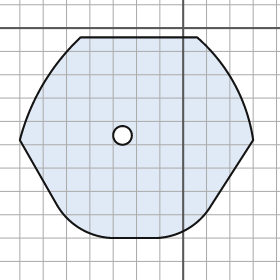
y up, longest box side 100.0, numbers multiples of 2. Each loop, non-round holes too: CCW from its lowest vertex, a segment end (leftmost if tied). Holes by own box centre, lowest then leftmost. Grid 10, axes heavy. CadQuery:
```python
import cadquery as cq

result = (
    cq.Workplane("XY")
    .moveTo(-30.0, -90.0)
    .lineTo(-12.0, -90.0)
    .threePointArc((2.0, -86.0), (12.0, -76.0))
    .lineTo(30.0, -48.0)
    .threePointArc((22.0, -24.0), (6.0, -4.0))
    .lineTo(-44.0, -4.0)
    .threePointArc((-60.0, -24.0), (-70.0, -48.0))
    .lineTo(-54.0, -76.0)
    .threePointArc((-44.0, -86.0), (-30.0, -90.0))
    .close()
    .moveTo(-26.0, -46.0)
    .circle(4.0)
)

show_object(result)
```